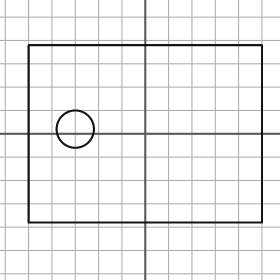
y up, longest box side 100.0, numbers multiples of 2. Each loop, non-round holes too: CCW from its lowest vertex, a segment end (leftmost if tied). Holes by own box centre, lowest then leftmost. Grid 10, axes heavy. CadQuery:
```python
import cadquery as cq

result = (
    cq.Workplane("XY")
    .moveTo(-50.0, -38.0)
    .lineTo(50.0, -38.0)
    .lineTo(50.0, 38.0)
    .lineTo(-50.0, 38.0)
    .close()
    .moveTo(-30.0, 2.0)
    .circle(8.0)
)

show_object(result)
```